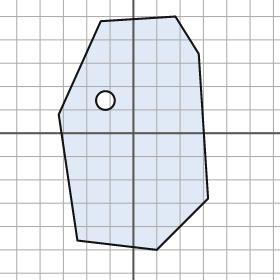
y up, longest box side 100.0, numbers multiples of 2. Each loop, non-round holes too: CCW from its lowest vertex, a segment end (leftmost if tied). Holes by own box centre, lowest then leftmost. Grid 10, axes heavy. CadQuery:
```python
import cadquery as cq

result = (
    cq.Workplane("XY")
    .moveTo(10.0, -50.0)
    .lineTo(32.0, -28.0)
    .lineTo(28.0, 34.0)
    .lineTo(18.0, 50.0)
    .lineTo(-14.0, 48.0)
    .lineTo(-32.0, 8.0)
    .lineTo(-24.0, -46.0)
    .close()
    .moveTo(-12.0, 14.0)
    .circle(4.0)
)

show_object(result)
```